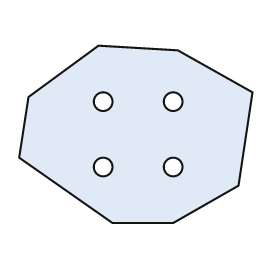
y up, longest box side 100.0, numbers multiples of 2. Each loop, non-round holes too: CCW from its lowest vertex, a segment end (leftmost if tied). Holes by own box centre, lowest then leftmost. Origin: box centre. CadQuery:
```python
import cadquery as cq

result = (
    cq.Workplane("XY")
    .moveTo(-10.0, -38.0)
    .lineTo(16.0, -38.0)
    .lineTo(44.0, -22.0)
    .lineTo(50.0, 18.0)
    .lineTo(18.0, 36.0)
    .lineTo(-16.0, 38.0)
    .lineTo(-46.0, 16.0)
    .lineTo(-50.0, -10.0)
    .close()
    .moveTo(-14.0, -14.0)
    .circle(4.0)
    .moveTo(16.0, -14.0)
    .circle(4.0)
    .moveTo(-14.0, 14.0)
    .circle(4.0)
    .moveTo(16.0, 14.0)
    .circle(4.0)
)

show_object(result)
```